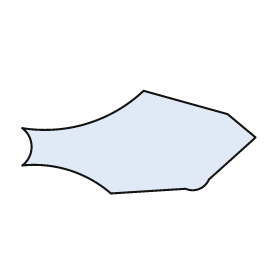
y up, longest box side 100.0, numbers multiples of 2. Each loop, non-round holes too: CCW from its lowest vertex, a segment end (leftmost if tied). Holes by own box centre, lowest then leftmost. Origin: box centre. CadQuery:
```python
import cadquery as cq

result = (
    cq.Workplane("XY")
    .moveTo(-12.0, -22.0)
    .lineTo(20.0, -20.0)
    .threePointArc((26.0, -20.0), (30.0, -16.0))
    .lineTo(50.0, 2.0)
    .lineTo(38.0, 12.0)
    .lineTo(2.0, 22.0)
    .threePointArc((-22.0, 8.0), (-50.0, 6.0))
    .threePointArc((-46.0, -2.0), (-50.0, -10.0))
    .threePointArc((-30.0, -12.0), (-12.0, -22.0))
    .close()
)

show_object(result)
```